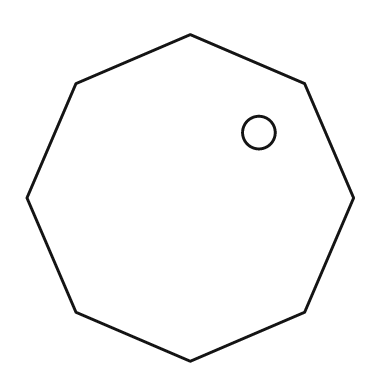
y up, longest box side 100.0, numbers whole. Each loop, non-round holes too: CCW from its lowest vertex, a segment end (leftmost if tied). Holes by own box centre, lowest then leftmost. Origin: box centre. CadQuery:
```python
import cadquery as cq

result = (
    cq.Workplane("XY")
    .moveTo(0.0, -50.0)
    .lineTo(35.0, -35.0)
    .lineTo(50.0, 0.0)
    .lineTo(35.0, 35.0)
    .lineTo(0.0, 50.0)
    .lineTo(-35.0, 35.0)
    .lineTo(-50.0, 0.0)
    .lineTo(-35.0, -35.0)
    .close()
    .moveTo(21.0, 20.0)
    .circle(5.0)
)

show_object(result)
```